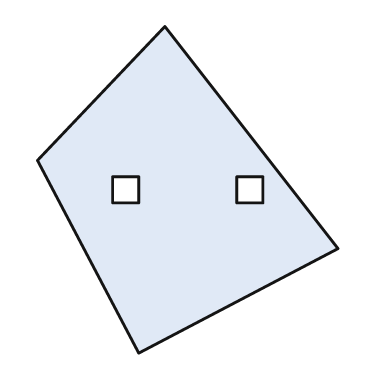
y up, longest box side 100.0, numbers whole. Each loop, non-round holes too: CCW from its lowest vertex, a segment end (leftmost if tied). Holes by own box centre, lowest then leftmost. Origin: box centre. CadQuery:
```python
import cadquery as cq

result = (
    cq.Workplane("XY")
    .moveTo(-15.0, -50.0)
    .lineTo(46.0, -18.0)
    .lineTo(-7.0, 50.0)
    .lineTo(-46.0, 9.0)
    .close()
    .moveTo(-23.0, -4.0)
    .lineTo(-15.0, -4.0)
    .lineTo(-15.0, 4.0)
    .lineTo(-23.0, 4.0)
    .close()
    .moveTo(15.0, -4.0)
    .lineTo(23.0, -4.0)
    .lineTo(23.0, 4.0)
    .lineTo(15.0, 4.0)
    .close()
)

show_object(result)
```